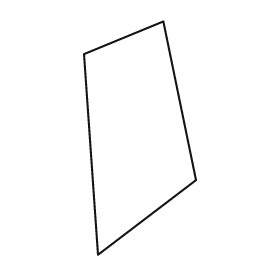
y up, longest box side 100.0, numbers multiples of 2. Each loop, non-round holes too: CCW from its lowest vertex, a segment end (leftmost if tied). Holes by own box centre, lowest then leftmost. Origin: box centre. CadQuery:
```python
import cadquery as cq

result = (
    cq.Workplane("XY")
    .moveTo(-18.0, -50.0)
    .lineTo(24.0, -18.0)
    .lineTo(10.0, 50.0)
    .lineTo(-24.0, 36.0)
    .close()
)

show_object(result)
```